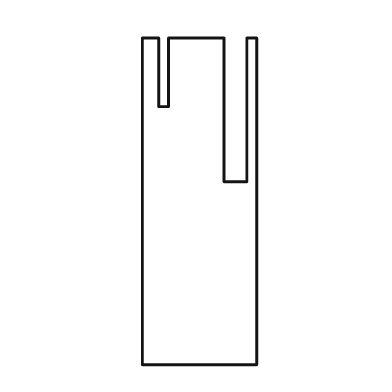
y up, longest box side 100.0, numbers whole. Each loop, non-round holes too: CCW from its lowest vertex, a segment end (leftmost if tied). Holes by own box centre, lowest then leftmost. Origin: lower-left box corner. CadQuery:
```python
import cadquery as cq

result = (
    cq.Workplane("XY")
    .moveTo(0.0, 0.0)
    .lineTo(35.0, 0.0)
    .lineTo(35.0, 100.0)
    .lineTo(32.0, 100.0)
    .lineTo(32.0, 56.0)
    .lineTo(25.0, 56.0)
    .lineTo(25.0, 100.0)
    .lineTo(8.0, 100.0)
    .lineTo(8.0, 79.0)
    .lineTo(5.0, 79.0)
    .lineTo(5.0, 100.0)
    .lineTo(0.0, 100.0)
    .close()
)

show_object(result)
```